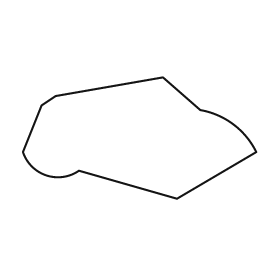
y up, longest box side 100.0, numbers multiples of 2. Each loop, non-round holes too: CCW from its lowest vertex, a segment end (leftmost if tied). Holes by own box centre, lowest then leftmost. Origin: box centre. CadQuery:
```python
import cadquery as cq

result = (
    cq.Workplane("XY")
    .moveTo(16.0, -26.0)
    .lineTo(50.0, -6.0)
    .threePointArc((40.0, 6.0), (26.0, 12.0))
    .lineTo(10.0, 26.0)
    .lineTo(-36.0, 18.0)
    .lineTo(-42.0, 14.0)
    .lineTo(-50.0, -6.0)
    .threePointArc((-40.0, -16.0), (-26.0, -14.0))
    .close()
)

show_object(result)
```